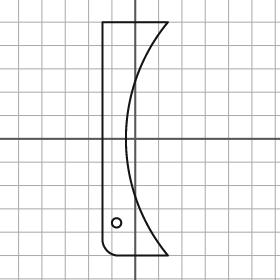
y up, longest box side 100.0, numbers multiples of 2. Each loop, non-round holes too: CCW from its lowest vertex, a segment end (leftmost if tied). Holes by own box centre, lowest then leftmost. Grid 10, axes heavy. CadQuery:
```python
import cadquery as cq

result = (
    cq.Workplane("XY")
    .moveTo(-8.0, -50.0)
    .lineTo(14.0, -50.0)
    .threePointArc((-4.0, 0.0), (14.0, 50.0))
    .lineTo(-14.0, 50.0)
    .lineTo(-14.0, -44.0)
    .threePointArc((-12.0, -48.0), (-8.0, -50.0))
    .close()
    .moveTo(-8.0, -36.0)
    .circle(2.0)
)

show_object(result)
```